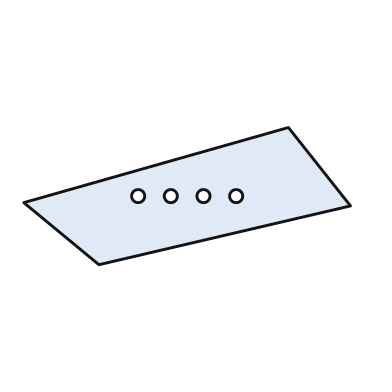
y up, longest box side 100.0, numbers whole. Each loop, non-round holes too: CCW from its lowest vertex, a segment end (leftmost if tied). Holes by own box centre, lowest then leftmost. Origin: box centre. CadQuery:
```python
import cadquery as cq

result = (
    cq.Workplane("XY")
    .moveTo(-27.0, -21.0)
    .lineTo(50.0, -3.0)
    .lineTo(31.0, 21.0)
    .lineTo(-50.0, -2.0)
    .close()
    .moveTo(-15.0, 0.0)
    .circle(2.0)
    .moveTo(-5.0, 0.0)
    .circle(2.0)
    .moveTo(5.0, 0.0)
    .circle(2.0)
    .moveTo(15.0, 0.0)
    .circle(2.0)
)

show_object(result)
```